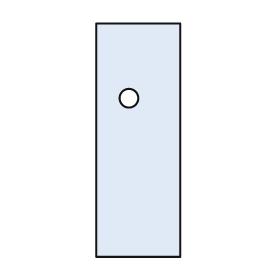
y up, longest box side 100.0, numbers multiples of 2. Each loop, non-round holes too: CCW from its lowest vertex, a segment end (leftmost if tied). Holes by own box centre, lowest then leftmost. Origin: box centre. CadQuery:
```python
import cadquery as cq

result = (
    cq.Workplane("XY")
    .moveTo(-18.0, -50.0)
    .lineTo(18.0, -50.0)
    .lineTo(18.0, 50.0)
    .lineTo(-18.0, 50.0)
    .close()
    .moveTo(-4.0, 18.0)
    .circle(4.0)
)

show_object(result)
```